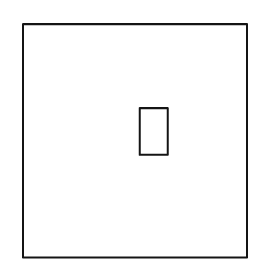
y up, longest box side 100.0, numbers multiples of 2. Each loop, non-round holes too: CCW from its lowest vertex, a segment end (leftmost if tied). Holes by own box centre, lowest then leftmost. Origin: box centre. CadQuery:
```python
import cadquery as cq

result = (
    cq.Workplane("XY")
    .moveTo(-48.0, -50.0)
    .lineTo(48.0, -50.0)
    .lineTo(48.0, 50.0)
    .lineTo(-48.0, 50.0)
    .close()
    .moveTo(2.0, -6.0)
    .lineTo(14.0, -6.0)
    .lineTo(14.0, 14.0)
    .lineTo(2.0, 14.0)
    .close()
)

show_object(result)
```